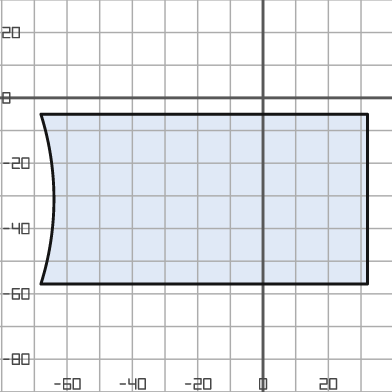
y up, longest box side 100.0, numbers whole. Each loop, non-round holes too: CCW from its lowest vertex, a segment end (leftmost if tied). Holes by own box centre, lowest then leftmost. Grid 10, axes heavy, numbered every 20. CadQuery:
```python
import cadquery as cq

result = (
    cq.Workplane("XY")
    .moveTo(-68.0, -57.0)
    .lineTo(32.0, -57.0)
    .lineTo(32.0, -5.0)
    .lineTo(-68.0, -5.0)
    .threePointArc((-64.0, -31.0), (-68.0, -57.0))
    .close()
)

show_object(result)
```